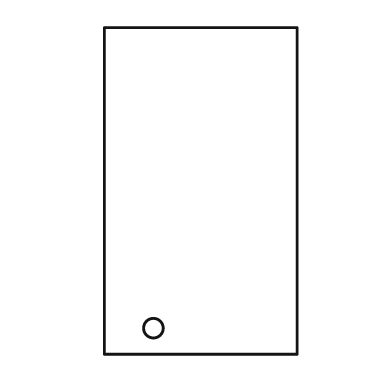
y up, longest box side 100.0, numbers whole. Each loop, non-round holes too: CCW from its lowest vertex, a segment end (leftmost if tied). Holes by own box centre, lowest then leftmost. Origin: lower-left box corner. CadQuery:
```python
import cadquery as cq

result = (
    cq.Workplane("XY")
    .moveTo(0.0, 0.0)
    .lineTo(59.0, 0.0)
    .lineTo(59.0, 100.0)
    .lineTo(0.0, 100.0)
    .close()
    .moveTo(15.0, 8.0)
    .circle(3.0)
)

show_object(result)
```